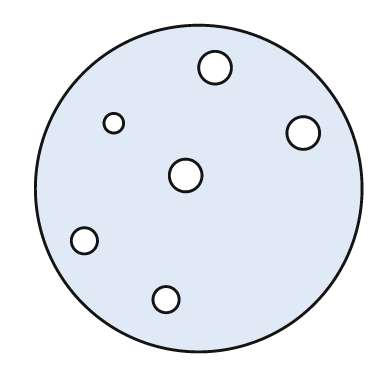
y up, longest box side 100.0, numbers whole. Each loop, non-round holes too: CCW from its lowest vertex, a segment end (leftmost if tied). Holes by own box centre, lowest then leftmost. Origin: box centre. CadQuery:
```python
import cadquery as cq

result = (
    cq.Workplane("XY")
    .moveTo(0.0, 0.0)
    .circle(50.0)
    .moveTo(-10.0, -34.0)
    .circle(4.0)
    .moveTo(-35.0, -16.0)
    .circle(4.0)
    .moveTo(-4.0, 4.0)
    .circle(5.0)
    .moveTo(32.0, 17.0)
    .circle(5.0)
    .moveTo(-26.0, 20.0)
    .circle(3.0)
    .moveTo(5.0, 37.0)
    .circle(5.0)
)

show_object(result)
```